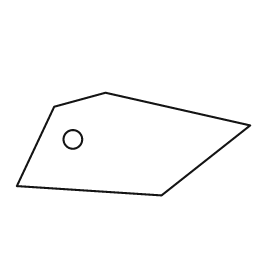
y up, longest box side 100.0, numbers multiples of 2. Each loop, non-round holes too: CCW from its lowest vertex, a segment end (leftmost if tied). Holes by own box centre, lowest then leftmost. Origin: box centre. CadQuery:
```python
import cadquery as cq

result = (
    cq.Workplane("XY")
    .moveTo(12.0, -22.0)
    .lineTo(50.0, 8.0)
    .lineTo(-12.0, 22.0)
    .lineTo(-34.0, 16.0)
    .lineTo(-50.0, -18.0)
    .close()
    .moveTo(-26.0, 2.0)
    .circle(4.0)
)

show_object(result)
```